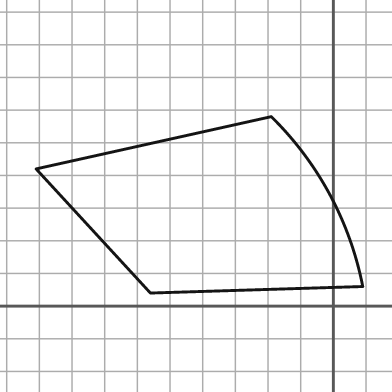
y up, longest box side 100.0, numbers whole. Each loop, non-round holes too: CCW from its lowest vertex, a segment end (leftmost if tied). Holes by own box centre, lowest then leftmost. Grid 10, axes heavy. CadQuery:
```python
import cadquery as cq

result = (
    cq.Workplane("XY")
    .moveTo(-56.0, 4.0)
    .lineTo(9.0, 6.0)
    .threePointArc((-1.0, 34.0), (-19.0, 58.0))
    .lineTo(-91.0, 42.0)
    .close()
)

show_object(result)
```